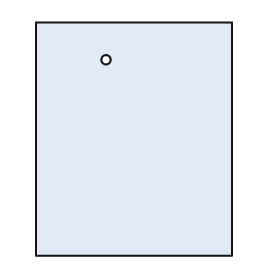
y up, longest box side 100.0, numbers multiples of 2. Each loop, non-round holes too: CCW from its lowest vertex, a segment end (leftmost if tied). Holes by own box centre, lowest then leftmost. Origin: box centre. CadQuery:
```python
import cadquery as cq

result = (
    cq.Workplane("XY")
    .moveTo(-42.0, -50.0)
    .lineTo(42.0, -50.0)
    .lineTo(42.0, 50.0)
    .lineTo(-42.0, 50.0)
    .close()
    .moveTo(-12.0, 34.0)
    .circle(2.0)
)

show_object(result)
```